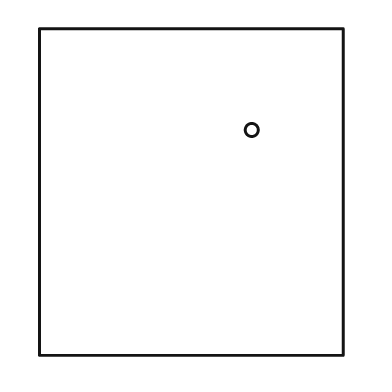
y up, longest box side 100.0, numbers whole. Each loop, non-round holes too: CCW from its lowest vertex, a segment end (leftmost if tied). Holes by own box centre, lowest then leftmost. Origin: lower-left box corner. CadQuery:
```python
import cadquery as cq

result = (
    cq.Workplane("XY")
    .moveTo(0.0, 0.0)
    .lineTo(93.0, 0.0)
    .lineTo(93.0, 100.0)
    .lineTo(0.0, 100.0)
    .close()
    .moveTo(65.0, 69.0)
    .circle(2.0)
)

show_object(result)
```